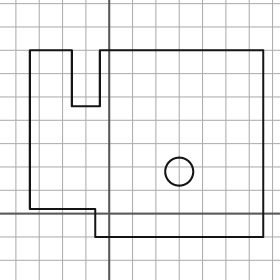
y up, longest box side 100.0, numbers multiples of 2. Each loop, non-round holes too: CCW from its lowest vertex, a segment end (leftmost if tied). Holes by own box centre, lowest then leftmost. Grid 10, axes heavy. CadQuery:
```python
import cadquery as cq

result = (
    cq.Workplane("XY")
    .moveTo(-6.0, -10.0)
    .lineTo(66.0, -10.0)
    .lineTo(66.0, 70.0)
    .lineTo(-4.0, 70.0)
    .lineTo(-4.0, 46.0)
    .lineTo(-16.0, 46.0)
    .lineTo(-16.0, 70.0)
    .lineTo(-34.0, 70.0)
    .lineTo(-34.0, 2.0)
    .lineTo(-6.0, 2.0)
    .close()
    .moveTo(30.0, 18.0)
    .circle(6.0)
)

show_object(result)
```